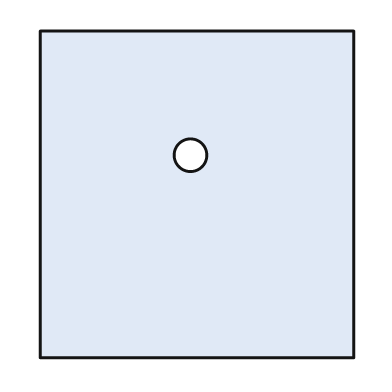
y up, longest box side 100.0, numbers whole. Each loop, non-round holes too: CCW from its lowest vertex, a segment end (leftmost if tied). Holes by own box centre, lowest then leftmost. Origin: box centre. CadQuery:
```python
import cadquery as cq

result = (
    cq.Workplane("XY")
    .moveTo(-48.0, -50.0)
    .lineTo(48.0, -50.0)
    .lineTo(48.0, 50.0)
    .lineTo(-48.0, 50.0)
    .close()
    .moveTo(-2.0, 12.0)
    .circle(5.0)
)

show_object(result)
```